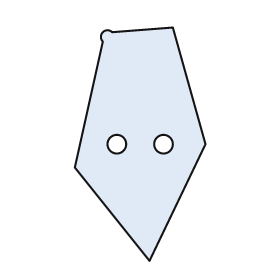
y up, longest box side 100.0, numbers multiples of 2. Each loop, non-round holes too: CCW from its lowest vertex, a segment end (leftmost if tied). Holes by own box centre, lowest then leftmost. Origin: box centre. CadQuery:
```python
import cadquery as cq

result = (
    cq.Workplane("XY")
    .moveTo(4.0, -50.0)
    .lineTo(28.0, 0.0)
    .lineTo(14.0, 50.0)
    .lineTo(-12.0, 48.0)
    .threePointArc((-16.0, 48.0), (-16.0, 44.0))
    .lineTo(-28.0, -10.0)
    .close()
    .moveTo(-10.0, 0.0)
    .circle(4.0)
    .moveTo(10.0, 0.0)
    .circle(4.0)
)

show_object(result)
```